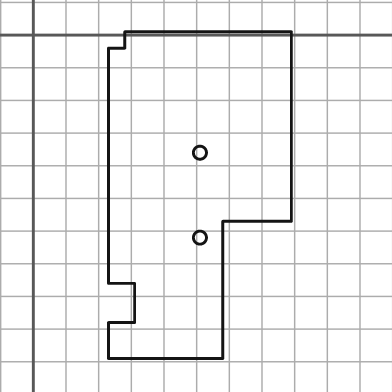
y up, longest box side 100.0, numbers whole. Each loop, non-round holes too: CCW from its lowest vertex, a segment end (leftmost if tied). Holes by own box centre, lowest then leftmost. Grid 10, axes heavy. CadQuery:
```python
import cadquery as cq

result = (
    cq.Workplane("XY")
    .moveTo(23.0, -99.0)
    .lineTo(58.0, -99.0)
    .lineTo(58.0, -57.0)
    .lineTo(79.0, -57.0)
    .lineTo(79.0, 1.0)
    .lineTo(28.0, 1.0)
    .lineTo(28.0, -4.0)
    .lineTo(23.0, -4.0)
    .lineTo(23.0, -76.0)
    .lineTo(31.0, -76.0)
    .lineTo(31.0, -88.0)
    .lineTo(23.0, -88.0)
    .close()
    .moveTo(51.0, -62.0)
    .circle(2.0)
    .moveTo(51.0, -36.0)
    .circle(2.0)
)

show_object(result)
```